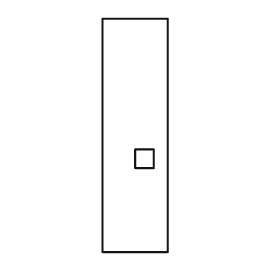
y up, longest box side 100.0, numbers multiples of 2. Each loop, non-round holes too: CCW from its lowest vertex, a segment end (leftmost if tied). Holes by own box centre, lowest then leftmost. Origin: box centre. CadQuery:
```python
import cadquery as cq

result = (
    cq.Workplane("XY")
    .moveTo(-14.0, -50.0)
    .lineTo(14.0, -50.0)
    .lineTo(14.0, 50.0)
    .lineTo(-14.0, 50.0)
    .close()
    .moveTo(0.0, -14.0)
    .lineTo(8.0, -14.0)
    .lineTo(8.0, -6.0)
    .lineTo(0.0, -6.0)
    .close()
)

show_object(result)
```